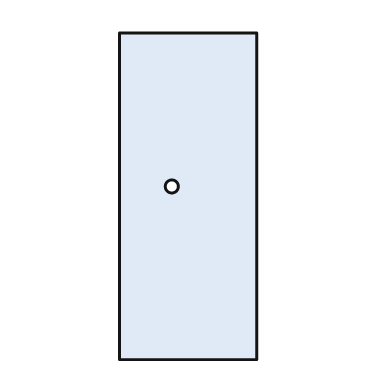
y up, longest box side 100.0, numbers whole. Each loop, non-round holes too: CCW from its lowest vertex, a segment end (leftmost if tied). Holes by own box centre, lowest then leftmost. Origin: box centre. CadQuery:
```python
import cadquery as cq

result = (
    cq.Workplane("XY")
    .moveTo(-21.0, -50.0)
    .lineTo(21.0, -50.0)
    .lineTo(21.0, 50.0)
    .lineTo(-21.0, 50.0)
    .close()
    .moveTo(-5.0, 3.0)
    .circle(2.0)
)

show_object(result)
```